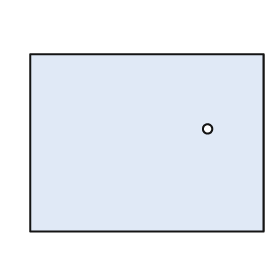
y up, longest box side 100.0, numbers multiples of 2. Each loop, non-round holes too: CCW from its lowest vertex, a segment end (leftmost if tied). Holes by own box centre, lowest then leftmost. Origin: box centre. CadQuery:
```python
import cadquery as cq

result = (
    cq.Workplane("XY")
    .moveTo(-50.0, -38.0)
    .lineTo(50.0, -38.0)
    .lineTo(50.0, 38.0)
    .lineTo(-50.0, 38.0)
    .close()
    .moveTo(26.0, 6.0)
    .circle(2.0)
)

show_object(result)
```